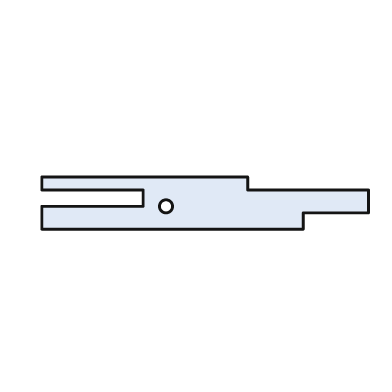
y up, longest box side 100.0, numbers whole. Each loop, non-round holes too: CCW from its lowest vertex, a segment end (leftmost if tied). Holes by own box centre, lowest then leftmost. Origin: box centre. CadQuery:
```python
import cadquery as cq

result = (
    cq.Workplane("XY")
    .moveTo(-50.0, -8.0)
    .lineTo(30.0, -8.0)
    .lineTo(30.0, -3.0)
    .lineTo(50.0, -3.0)
    .lineTo(50.0, 4.0)
    .lineTo(13.0, 4.0)
    .lineTo(13.0, 8.0)
    .lineTo(-50.0, 8.0)
    .lineTo(-50.0, 4.0)
    .lineTo(-19.0, 4.0)
    .lineTo(-19.0, -1.0)
    .lineTo(-50.0, -1.0)
    .close()
    .moveTo(-12.0, -1.0)
    .circle(2.0)
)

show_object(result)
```